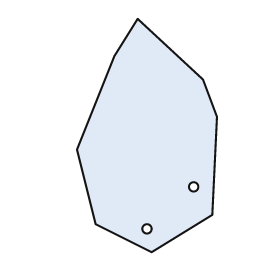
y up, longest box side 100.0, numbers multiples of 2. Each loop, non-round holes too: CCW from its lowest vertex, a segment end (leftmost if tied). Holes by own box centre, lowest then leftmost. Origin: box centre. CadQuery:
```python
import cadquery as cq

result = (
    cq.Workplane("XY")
    .moveTo(2.0, -50.0)
    .lineTo(28.0, -34.0)
    .lineTo(30.0, 8.0)
    .lineTo(24.0, 24.0)
    .lineTo(-4.0, 50.0)
    .lineTo(-14.0, 34.0)
    .lineTo(-30.0, -6.0)
    .lineTo(-22.0, -38.0)
    .close()
    .moveTo(0.0, -40.0)
    .circle(2.0)
    .moveTo(20.0, -22.0)
    .circle(2.0)
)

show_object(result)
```